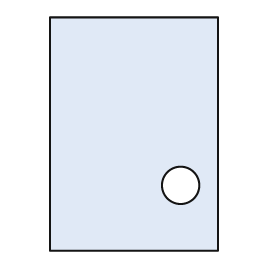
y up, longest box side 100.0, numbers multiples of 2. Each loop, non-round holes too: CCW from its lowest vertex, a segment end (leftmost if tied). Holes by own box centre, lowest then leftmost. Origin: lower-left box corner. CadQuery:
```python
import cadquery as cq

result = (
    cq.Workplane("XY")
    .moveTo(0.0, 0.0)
    .lineTo(72.0, 0.0)
    .lineTo(72.0, 100.0)
    .lineTo(0.0, 100.0)
    .close()
    .moveTo(56.0, 28.0)
    .circle(8.0)
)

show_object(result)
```